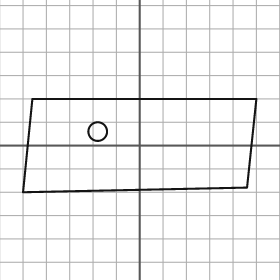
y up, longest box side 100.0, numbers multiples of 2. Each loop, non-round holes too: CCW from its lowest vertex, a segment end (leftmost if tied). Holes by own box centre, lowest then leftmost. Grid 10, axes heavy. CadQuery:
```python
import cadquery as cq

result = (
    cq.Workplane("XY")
    .moveTo(-50.0, -20.0)
    .lineTo(46.0, -18.0)
    .lineTo(50.0, 20.0)
    .lineTo(-46.0, 20.0)
    .close()
    .moveTo(-18.0, 6.0)
    .circle(4.0)
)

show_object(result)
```